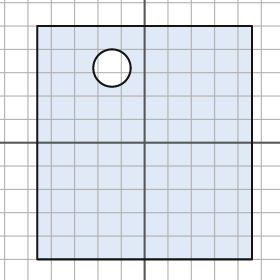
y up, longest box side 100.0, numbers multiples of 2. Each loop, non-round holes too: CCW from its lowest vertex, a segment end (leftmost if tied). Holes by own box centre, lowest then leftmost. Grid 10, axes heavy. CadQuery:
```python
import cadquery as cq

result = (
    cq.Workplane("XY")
    .moveTo(-46.0, -50.0)
    .lineTo(46.0, -50.0)
    .lineTo(46.0, 50.0)
    .lineTo(-46.0, 50.0)
    .close()
    .moveTo(-14.0, 32.0)
    .circle(8.0)
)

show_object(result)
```